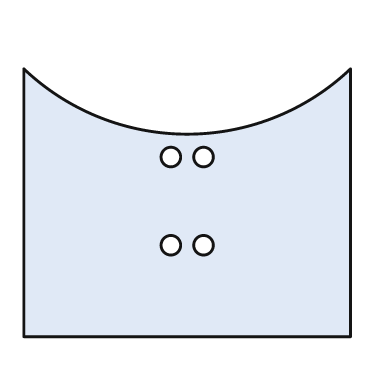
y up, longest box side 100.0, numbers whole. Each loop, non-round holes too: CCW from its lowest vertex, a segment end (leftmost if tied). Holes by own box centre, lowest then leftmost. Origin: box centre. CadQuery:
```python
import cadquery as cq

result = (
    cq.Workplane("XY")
    .moveTo(-50.0, -41.0)
    .lineTo(50.0, -41.0)
    .lineTo(50.0, 41.0)
    .threePointArc((0.0, 21.0), (-50.0, 41.0))
    .close()
    .moveTo(-5.0, -13.0)
    .circle(3.0)
    .moveTo(5.0, -13.0)
    .circle(3.0)
    .moveTo(-5.0, 14.0)
    .circle(3.0)
    .moveTo(5.0, 14.0)
    .circle(3.0)
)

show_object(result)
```